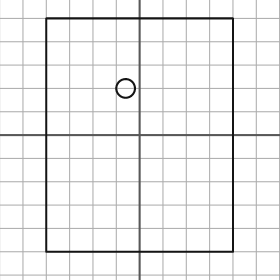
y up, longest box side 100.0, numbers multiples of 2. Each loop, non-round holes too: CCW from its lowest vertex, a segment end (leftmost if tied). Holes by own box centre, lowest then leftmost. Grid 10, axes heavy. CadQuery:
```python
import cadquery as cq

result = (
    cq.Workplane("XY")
    .moveTo(-40.0, -50.0)
    .lineTo(40.0, -50.0)
    .lineTo(40.0, 50.0)
    .lineTo(-40.0, 50.0)
    .close()
    .moveTo(-6.0, 20.0)
    .circle(4.0)
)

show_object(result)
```